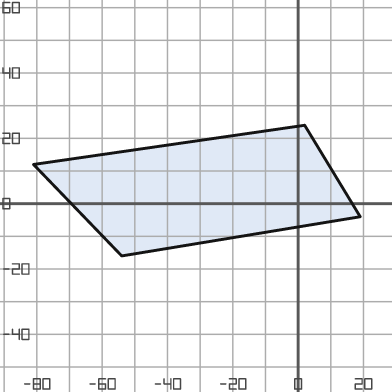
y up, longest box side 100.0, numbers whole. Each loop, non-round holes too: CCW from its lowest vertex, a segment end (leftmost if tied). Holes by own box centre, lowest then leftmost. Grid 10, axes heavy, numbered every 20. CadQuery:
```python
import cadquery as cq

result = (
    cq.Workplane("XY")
    .moveTo(-54.0, -16.0)
    .lineTo(19.0, -4.0)
    .lineTo(2.0, 24.0)
    .lineTo(-81.0, 12.0)
    .close()
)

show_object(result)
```